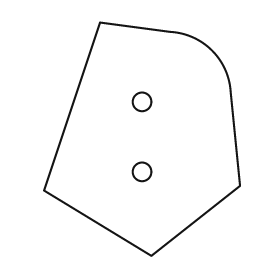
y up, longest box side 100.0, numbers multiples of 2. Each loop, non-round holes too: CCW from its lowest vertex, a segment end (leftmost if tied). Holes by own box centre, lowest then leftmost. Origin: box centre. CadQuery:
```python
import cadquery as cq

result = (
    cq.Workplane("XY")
    .moveTo(4.0, -50.0)
    .lineTo(42.0, -20.0)
    .lineTo(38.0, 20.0)
    .threePointArc((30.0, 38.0), (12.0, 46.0))
    .lineTo(-18.0, 50.0)
    .lineTo(-42.0, -22.0)
    .close()
    .moveTo(0.0, -14.0)
    .circle(4.0)
    .moveTo(0.0, 16.0)
    .circle(4.0)
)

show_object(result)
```